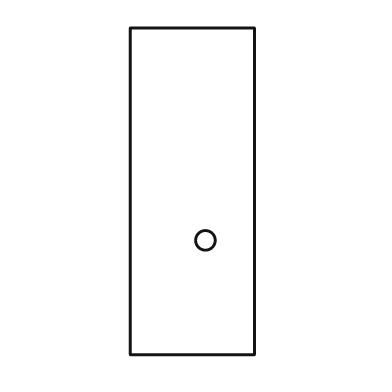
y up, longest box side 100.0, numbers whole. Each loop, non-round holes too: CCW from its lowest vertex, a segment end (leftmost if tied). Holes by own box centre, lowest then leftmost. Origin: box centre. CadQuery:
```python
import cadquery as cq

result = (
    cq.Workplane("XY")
    .moveTo(-19.0, -50.0)
    .lineTo(19.0, -50.0)
    .lineTo(19.0, 50.0)
    .lineTo(-19.0, 50.0)
    .close()
    .moveTo(4.0, -15.0)
    .circle(3.0)
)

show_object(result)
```